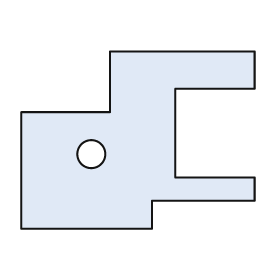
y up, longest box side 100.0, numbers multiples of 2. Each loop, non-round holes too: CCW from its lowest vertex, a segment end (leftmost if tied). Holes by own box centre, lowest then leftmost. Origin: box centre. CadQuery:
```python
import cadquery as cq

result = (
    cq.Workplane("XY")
    .moveTo(-50.0, -38.0)
    .lineTo(6.0, -38.0)
    .lineTo(6.0, -26.0)
    .lineTo(50.0, -26.0)
    .lineTo(50.0, -16.0)
    .lineTo(16.0, -16.0)
    .lineTo(16.0, 22.0)
    .lineTo(50.0, 22.0)
    .lineTo(50.0, 38.0)
    .lineTo(-12.0, 38.0)
    .lineTo(-12.0, 12.0)
    .lineTo(-50.0, 12.0)
    .close()
    .moveTo(-20.0, -6.0)
    .circle(6.0)
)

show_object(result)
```